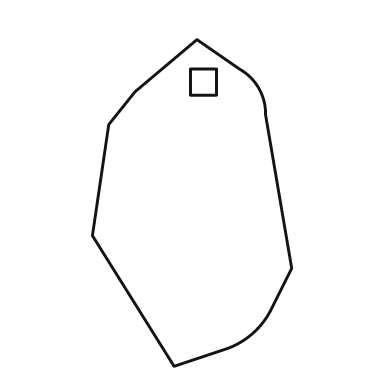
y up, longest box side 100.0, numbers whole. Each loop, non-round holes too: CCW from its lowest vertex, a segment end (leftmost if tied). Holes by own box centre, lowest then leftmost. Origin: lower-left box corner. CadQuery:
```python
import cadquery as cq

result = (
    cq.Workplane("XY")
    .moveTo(25.0, 0.0)
    .lineTo(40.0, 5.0)
    .threePointArc((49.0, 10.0), (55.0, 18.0))
    .lineTo(61.0, 30.0)
    .lineTo(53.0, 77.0)
    .threePointArc((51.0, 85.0), (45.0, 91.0))
    .lineTo(32.0, 100.0)
    .lineTo(13.0, 84.0)
    .lineTo(5.0, 74.0)
    .lineTo(0.0, 40.0)
    .close()
    .moveTo(30.0, 83.0)
    .lineTo(38.0, 83.0)
    .lineTo(38.0, 91.0)
    .lineTo(30.0, 91.0)
    .close()
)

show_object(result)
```